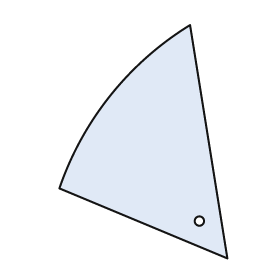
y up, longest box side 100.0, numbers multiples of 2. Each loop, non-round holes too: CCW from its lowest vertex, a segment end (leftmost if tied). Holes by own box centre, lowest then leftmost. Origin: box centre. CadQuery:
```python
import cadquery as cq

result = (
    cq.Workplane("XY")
    .moveTo(36.0, -50.0)
    .lineTo(20.0, 50.0)
    .threePointArc((-14.0, 20.0), (-36.0, -20.0))
    .close()
    .moveTo(24.0, -34.0)
    .circle(2.0)
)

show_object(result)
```